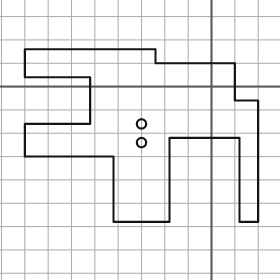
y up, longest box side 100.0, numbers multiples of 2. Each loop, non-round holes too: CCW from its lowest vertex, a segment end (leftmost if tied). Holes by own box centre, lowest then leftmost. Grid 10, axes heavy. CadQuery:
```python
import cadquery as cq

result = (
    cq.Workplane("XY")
    .moveTo(-42.0, -58.0)
    .lineTo(-18.0, -58.0)
    .lineTo(-18.0, -22.0)
    .lineTo(12.0, -22.0)
    .lineTo(12.0, -58.0)
    .lineTo(20.0, -58.0)
    .lineTo(20.0, -6.0)
    .lineTo(10.0, -6.0)
    .lineTo(10.0, 10.0)
    .lineTo(-24.0, 10.0)
    .lineTo(-24.0, 16.0)
    .lineTo(-80.0, 16.0)
    .lineTo(-80.0, 4.0)
    .lineTo(-52.0, 4.0)
    .lineTo(-52.0, -16.0)
    .lineTo(-80.0, -16.0)
    .lineTo(-80.0, -30.0)
    .lineTo(-42.0, -30.0)
    .close()
    .moveTo(-30.0, -24.0)
    .circle(2.0)
    .moveTo(-30.0, -16.0)
    .circle(2.0)
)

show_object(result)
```